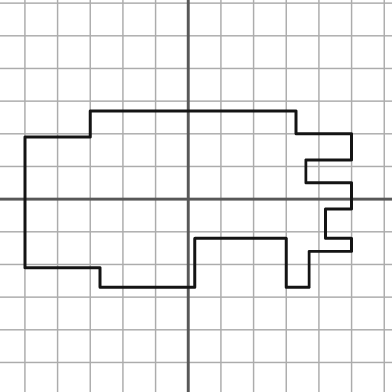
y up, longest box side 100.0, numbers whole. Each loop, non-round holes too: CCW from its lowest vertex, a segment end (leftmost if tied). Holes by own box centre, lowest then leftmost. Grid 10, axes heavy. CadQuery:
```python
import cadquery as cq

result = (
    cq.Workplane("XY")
    .moveTo(-27.0, -27.0)
    .lineTo(2.0, -27.0)
    .lineTo(2.0, -12.0)
    .lineTo(30.0, -12.0)
    .lineTo(30.0, -27.0)
    .lineTo(37.0, -27.0)
    .lineTo(37.0, -16.0)
    .lineTo(50.0, -16.0)
    .lineTo(50.0, -12.0)
    .lineTo(42.0, -12.0)
    .lineTo(42.0, -3.0)
    .lineTo(50.0, -3.0)
    .lineTo(50.0, 5.0)
    .lineTo(36.0, 5.0)
    .lineTo(36.0, 12.0)
    .lineTo(50.0, 12.0)
    .lineTo(50.0, 20.0)
    .lineTo(33.0, 20.0)
    .lineTo(33.0, 27.0)
    .lineTo(-30.0, 27.0)
    .lineTo(-30.0, 19.0)
    .lineTo(-50.0, 19.0)
    .lineTo(-50.0, -21.0)
    .lineTo(-27.0, -21.0)
    .close()
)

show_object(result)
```